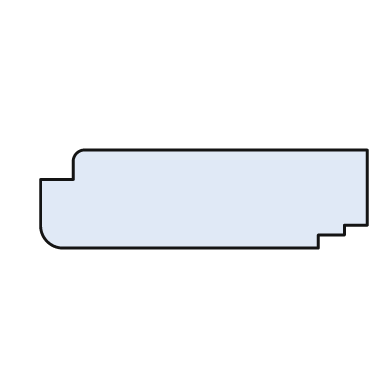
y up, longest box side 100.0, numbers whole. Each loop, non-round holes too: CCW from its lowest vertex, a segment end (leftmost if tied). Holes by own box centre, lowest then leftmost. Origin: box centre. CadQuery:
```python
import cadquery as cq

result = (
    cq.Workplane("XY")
    .moveTo(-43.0, -15.0)
    .lineTo(35.0, -15.0)
    .lineTo(35.0, -11.0)
    .lineTo(43.0, -11.0)
    .lineTo(43.0, -8.0)
    .lineTo(50.0, -8.0)
    .lineTo(50.0, 15.0)
    .lineTo(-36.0, 15.0)
    .threePointArc((-39.0, 14.0), (-40.0, 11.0))
    .lineTo(-40.0, 6.0)
    .lineTo(-50.0, 6.0)
    .lineTo(-50.0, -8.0)
    .threePointArc((-48.0, -13.0), (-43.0, -15.0))
    .close()
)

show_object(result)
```